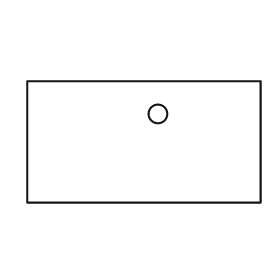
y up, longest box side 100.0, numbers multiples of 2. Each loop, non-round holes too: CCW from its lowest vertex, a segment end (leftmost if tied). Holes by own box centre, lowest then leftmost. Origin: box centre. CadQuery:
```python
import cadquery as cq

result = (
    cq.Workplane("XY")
    .moveTo(-50.0, -26.0)
    .lineTo(50.0, -26.0)
    .lineTo(50.0, 26.0)
    .lineTo(-50.0, 26.0)
    .close()
    .moveTo(6.0, 12.0)
    .circle(4.0)
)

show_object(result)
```